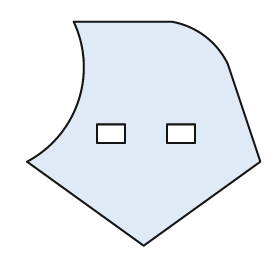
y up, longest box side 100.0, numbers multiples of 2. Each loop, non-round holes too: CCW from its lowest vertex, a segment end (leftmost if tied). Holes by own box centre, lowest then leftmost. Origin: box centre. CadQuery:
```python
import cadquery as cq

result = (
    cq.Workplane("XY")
    .moveTo(0.0, -48.0)
    .lineTo(50.0, -12.0)
    .lineTo(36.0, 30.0)
    .threePointArc((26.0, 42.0), (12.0, 48.0))
    .lineTo(-30.0, 48.0)
    .threePointArc((-28.0, 14.0), (-50.0, -12.0))
    .close()
    .moveTo(-20.0, -4.0)
    .lineTo(-8.0, -4.0)
    .lineTo(-8.0, 4.0)
    .lineTo(-20.0, 4.0)
    .close()
    .moveTo(10.0, -4.0)
    .lineTo(22.0, -4.0)
    .lineTo(22.0, 4.0)
    .lineTo(10.0, 4.0)
    .close()
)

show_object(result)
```